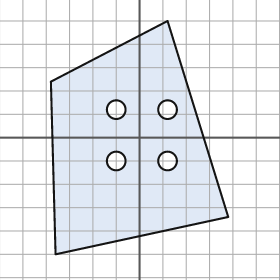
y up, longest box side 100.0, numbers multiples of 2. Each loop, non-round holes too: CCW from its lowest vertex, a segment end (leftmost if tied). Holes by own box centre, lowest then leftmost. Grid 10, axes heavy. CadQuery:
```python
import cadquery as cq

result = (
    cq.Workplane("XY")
    .moveTo(-36.0, -50.0)
    .lineTo(38.0, -34.0)
    .lineTo(12.0, 50.0)
    .lineTo(-38.0, 24.0)
    .close()
    .moveTo(-10.0, -10.0)
    .circle(4.0)
    .moveTo(12.0, -10.0)
    .circle(4.0)
    .moveTo(-10.0, 12.0)
    .circle(4.0)
    .moveTo(12.0, 12.0)
    .circle(4.0)
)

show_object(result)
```